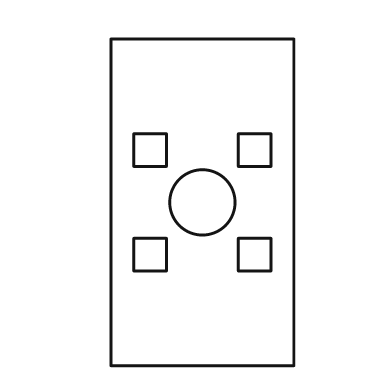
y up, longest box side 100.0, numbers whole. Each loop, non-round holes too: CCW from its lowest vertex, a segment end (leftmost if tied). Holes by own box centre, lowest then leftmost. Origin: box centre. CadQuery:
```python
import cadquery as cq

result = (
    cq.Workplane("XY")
    .moveTo(-28.0, -50.0)
    .lineTo(28.0, -50.0)
    .lineTo(28.0, 50.0)
    .lineTo(-28.0, 50.0)
    .close()
    .moveTo(-21.0, -21.0)
    .lineTo(-11.0, -21.0)
    .lineTo(-11.0, -11.0)
    .lineTo(-21.0, -11.0)
    .close()
    .moveTo(11.0, -21.0)
    .lineTo(21.0, -21.0)
    .lineTo(21.0, -11.0)
    .lineTo(11.0, -11.0)
    .close()
    .moveTo(0.0, 0.0)
    .circle(10.0)
    .moveTo(-21.0, 11.0)
    .lineTo(-11.0, 11.0)
    .lineTo(-11.0, 21.0)
    .lineTo(-21.0, 21.0)
    .close()
    .moveTo(11.0, 11.0)
    .lineTo(21.0, 11.0)
    .lineTo(21.0, 21.0)
    .lineTo(11.0, 21.0)
    .close()
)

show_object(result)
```